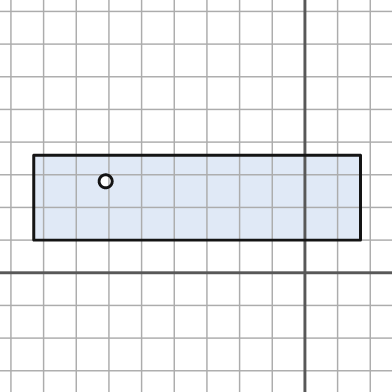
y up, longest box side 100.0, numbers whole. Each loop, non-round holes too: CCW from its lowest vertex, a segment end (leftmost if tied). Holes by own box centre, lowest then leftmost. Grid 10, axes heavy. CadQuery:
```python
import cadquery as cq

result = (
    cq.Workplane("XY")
    .moveTo(-83.0, 10.0)
    .lineTo(17.0, 10.0)
    .lineTo(17.0, 36.0)
    .lineTo(-83.0, 36.0)
    .close()
    .moveTo(-61.0, 28.0)
    .circle(2.0)
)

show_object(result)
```